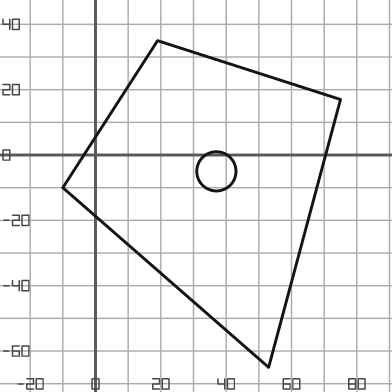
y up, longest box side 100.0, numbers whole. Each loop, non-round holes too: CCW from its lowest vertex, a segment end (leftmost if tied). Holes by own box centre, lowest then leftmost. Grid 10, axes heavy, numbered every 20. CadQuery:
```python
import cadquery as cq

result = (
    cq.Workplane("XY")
    .moveTo(53.0, -65.0)
    .lineTo(75.0, 17.0)
    .lineTo(19.0, 35.0)
    .lineTo(-10.0, -10.0)
    .close()
    .moveTo(37.0, -5.0)
    .circle(6.0)
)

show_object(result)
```